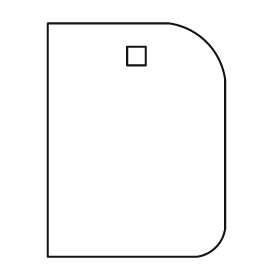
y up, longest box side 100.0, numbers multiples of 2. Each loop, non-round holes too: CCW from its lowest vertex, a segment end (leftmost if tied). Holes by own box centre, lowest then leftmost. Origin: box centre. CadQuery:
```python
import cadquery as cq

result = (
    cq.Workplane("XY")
    .moveTo(-38.0, -50.0)
    .lineTo(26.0, -50.0)
    .threePointArc((34.0, -46.0), (38.0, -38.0))
    .lineTo(38.0, 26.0)
    .threePointArc((30.0, 42.0), (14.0, 50.0))
    .lineTo(-38.0, 50.0)
    .close()
    .moveTo(-4.0, 32.0)
    .lineTo(4.0, 32.0)
    .lineTo(4.0, 40.0)
    .lineTo(-4.0, 40.0)
    .close()
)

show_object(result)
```